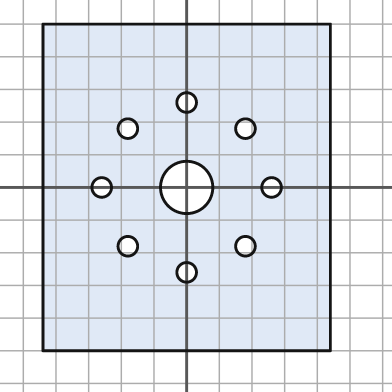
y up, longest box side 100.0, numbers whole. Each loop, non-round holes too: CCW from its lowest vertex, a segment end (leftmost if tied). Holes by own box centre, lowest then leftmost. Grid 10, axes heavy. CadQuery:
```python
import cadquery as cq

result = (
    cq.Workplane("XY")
    .moveTo(-44.0, -50.0)
    .lineTo(44.0, -50.0)
    .lineTo(44.0, 50.0)
    .lineTo(-44.0, 50.0)
    .close()
    .moveTo(0.0, -26.0)
    .circle(3.0)
    .moveTo(-18.0, -18.0)
    .circle(3.0)
    .moveTo(18.0, -18.0)
    .circle(3.0)
    .moveTo(-26.0, 0.0)
    .circle(3.0)
    .moveTo(0.0, 0.0)
    .circle(8.0)
    .moveTo(26.0, 0.0)
    .circle(3.0)
    .moveTo(-18.0, 18.0)
    .circle(3.0)
    .moveTo(18.0, 18.0)
    .circle(3.0)
    .moveTo(0.0, 26.0)
    .circle(3.0)
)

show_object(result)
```